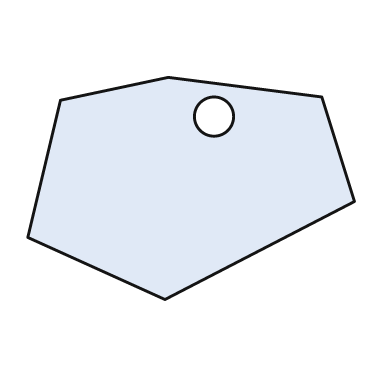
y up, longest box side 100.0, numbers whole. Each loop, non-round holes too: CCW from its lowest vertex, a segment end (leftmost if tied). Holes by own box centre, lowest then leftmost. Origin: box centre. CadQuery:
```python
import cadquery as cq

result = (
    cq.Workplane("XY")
    .moveTo(-8.0, -34.0)
    .lineTo(50.0, -4.0)
    .lineTo(40.0, 28.0)
    .lineTo(-7.0, 34.0)
    .lineTo(-40.0, 27.0)
    .lineTo(-50.0, -15.0)
    .close()
    .moveTo(7.0, 22.0)
    .circle(6.0)
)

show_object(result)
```